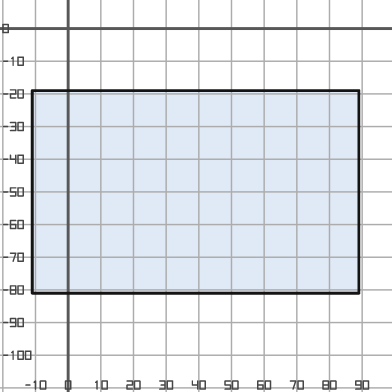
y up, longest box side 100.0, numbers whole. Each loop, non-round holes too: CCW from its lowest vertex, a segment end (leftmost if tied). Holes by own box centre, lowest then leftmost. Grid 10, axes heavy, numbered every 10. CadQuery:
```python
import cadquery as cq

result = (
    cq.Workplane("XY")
    .moveTo(-11.0, -81.0)
    .lineTo(89.0, -81.0)
    .lineTo(89.0, -19.0)
    .lineTo(-11.0, -19.0)
    .close()
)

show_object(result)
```